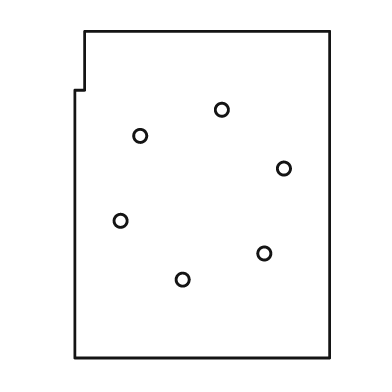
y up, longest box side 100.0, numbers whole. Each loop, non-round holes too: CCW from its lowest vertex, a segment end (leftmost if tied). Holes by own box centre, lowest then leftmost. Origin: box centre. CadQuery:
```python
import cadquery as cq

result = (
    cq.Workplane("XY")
    .moveTo(-39.0, -50.0)
    .lineTo(39.0, -50.0)
    .lineTo(39.0, 50.0)
    .lineTo(-36.0, 50.0)
    .lineTo(-36.0, 32.0)
    .lineTo(-39.0, 32.0)
    .close()
    .moveTo(-6.0, -26.0)
    .circle(2.0)
    .moveTo(19.0, -18.0)
    .circle(2.0)
    .moveTo(-25.0, -8.0)
    .circle(2.0)
    .moveTo(25.0, 8.0)
    .circle(2.0)
    .moveTo(-19.0, 18.0)
    .circle(2.0)
    .moveTo(6.0, 26.0)
    .circle(2.0)
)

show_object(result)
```